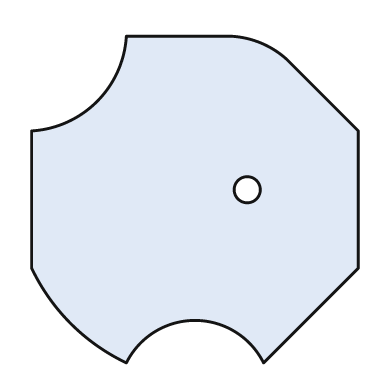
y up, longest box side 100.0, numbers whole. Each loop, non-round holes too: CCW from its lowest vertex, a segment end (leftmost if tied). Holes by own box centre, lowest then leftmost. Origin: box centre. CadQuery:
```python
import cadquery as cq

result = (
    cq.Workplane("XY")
    .moveTo(-21.0, -50.0)
    .threePointArc((0.0, -37.0), (21.0, -50.0))
    .lineTo(50.0, -21.0)
    .lineTo(50.0, 21.0)
    .lineTo(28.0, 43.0)
    .threePointArc((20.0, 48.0), (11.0, 50.0))
    .lineTo(-21.0, 50.0)
    .threePointArc((-30.0, 30.0), (-50.0, 21.0))
    .lineTo(-50.0, -21.0)
    .threePointArc((-38.0, -38.0), (-21.0, -50.0))
    .close()
    .moveTo(16.0, 3.0)
    .circle(4.0)
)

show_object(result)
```